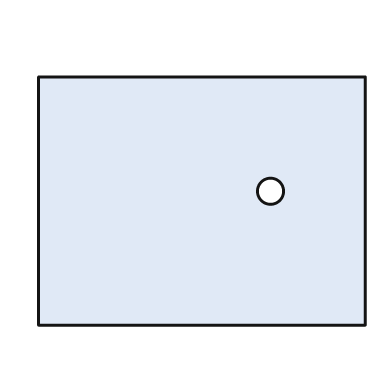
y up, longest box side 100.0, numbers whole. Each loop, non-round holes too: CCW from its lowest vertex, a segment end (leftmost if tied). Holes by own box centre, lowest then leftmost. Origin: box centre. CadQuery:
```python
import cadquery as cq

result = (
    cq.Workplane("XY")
    .moveTo(-50.0, -38.0)
    .lineTo(50.0, -38.0)
    .lineTo(50.0, 38.0)
    .lineTo(-50.0, 38.0)
    .close()
    .moveTo(21.0, 3.0)
    .circle(4.0)
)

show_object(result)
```